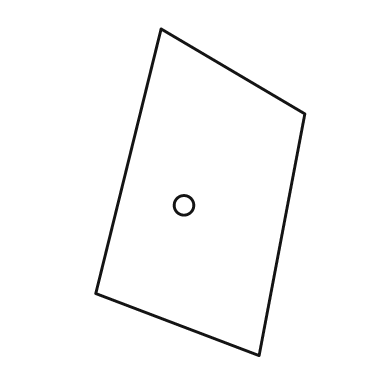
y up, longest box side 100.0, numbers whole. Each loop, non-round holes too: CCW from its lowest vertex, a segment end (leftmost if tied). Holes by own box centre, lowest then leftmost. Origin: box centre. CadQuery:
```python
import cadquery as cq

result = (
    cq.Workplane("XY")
    .moveTo(18.0, -50.0)
    .lineTo(32.0, 24.0)
    .lineTo(-12.0, 50.0)
    .lineTo(-32.0, -31.0)
    .close()
    .moveTo(-5.0, -4.0)
    .circle(3.0)
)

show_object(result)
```